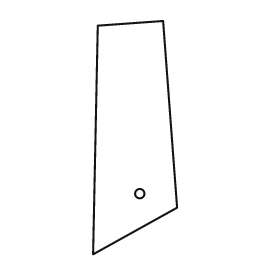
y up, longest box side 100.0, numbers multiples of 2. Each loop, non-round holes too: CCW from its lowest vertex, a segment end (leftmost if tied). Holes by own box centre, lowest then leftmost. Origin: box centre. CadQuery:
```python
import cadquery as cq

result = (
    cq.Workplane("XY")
    .moveTo(-18.0, -50.0)
    .lineTo(18.0, -30.0)
    .lineTo(12.0, 50.0)
    .lineTo(-16.0, 48.0)
    .close()
    .moveTo(2.0, -24.0)
    .circle(2.0)
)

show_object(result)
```